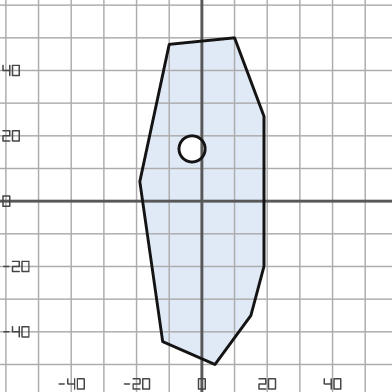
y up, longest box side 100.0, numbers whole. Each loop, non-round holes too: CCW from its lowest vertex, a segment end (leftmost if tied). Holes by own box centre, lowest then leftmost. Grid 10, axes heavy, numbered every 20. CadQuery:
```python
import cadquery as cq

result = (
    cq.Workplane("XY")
    .moveTo(4.0, -50.0)
    .lineTo(15.0, -35.0)
    .lineTo(19.0, -20.0)
    .lineTo(19.0, 26.0)
    .lineTo(10.0, 50.0)
    .lineTo(-10.0, 48.0)
    .lineTo(-19.0, 6.0)
    .lineTo(-12.0, -43.0)
    .close()
    .moveTo(-3.0, 16.0)
    .circle(4.0)
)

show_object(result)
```